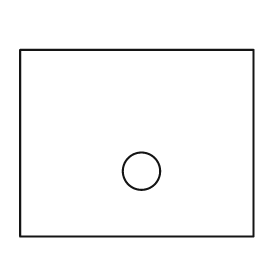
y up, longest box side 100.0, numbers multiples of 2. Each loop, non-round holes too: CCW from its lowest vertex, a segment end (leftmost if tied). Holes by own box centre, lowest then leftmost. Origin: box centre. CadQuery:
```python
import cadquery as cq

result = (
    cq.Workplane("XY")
    .moveTo(-50.0, -40.0)
    .lineTo(50.0, -40.0)
    .lineTo(50.0, 40.0)
    .lineTo(-50.0, 40.0)
    .close()
    .moveTo(2.0, -12.0)
    .circle(8.0)
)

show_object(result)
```